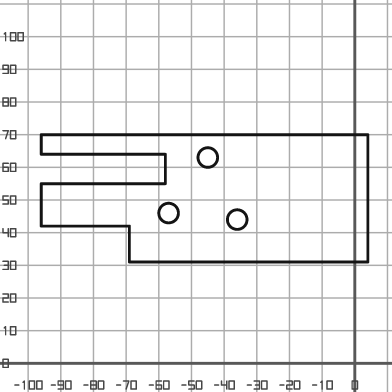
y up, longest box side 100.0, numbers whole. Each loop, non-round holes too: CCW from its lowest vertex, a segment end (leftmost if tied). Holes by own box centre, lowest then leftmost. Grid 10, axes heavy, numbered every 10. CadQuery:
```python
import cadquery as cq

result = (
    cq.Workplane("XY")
    .moveTo(-69.0, 31.0)
    .lineTo(4.0, 31.0)
    .lineTo(4.0, 70.0)
    .lineTo(-96.0, 70.0)
    .lineTo(-96.0, 64.0)
    .lineTo(-58.0, 64.0)
    .lineTo(-58.0, 55.0)
    .lineTo(-96.0, 55.0)
    .lineTo(-96.0, 42.0)
    .lineTo(-69.0, 42.0)
    .close()
    .moveTo(-36.0, 44.0)
    .circle(3.0)
    .moveTo(-57.0, 46.0)
    .circle(3.0)
    .moveTo(-45.0, 63.0)
    .circle(3.0)
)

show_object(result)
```